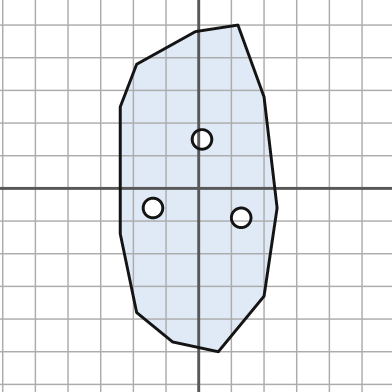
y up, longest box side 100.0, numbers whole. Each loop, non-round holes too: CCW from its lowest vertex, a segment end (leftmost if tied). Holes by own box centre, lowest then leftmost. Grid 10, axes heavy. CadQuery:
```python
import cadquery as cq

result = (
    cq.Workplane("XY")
    .moveTo(6.0, -50.0)
    .lineTo(20.0, -33.0)
    .lineTo(24.0, -6.0)
    .lineTo(20.0, 28.0)
    .lineTo(12.0, 50.0)
    .lineTo(-1.0, 48.0)
    .lineTo(-19.0, 38.0)
    .lineTo(-24.0, 25.0)
    .lineTo(-24.0, -14.0)
    .lineTo(-19.0, -38.0)
    .lineTo(-8.0, -47.0)
    .close()
    .moveTo(13.0, -9.0)
    .circle(3.0)
    .moveTo(-14.0, -6.0)
    .circle(3.0)
    .moveTo(1.0, 15.0)
    .circle(3.0)
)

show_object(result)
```